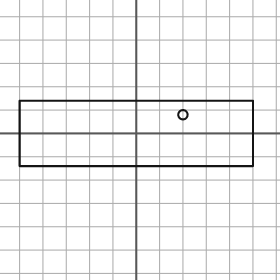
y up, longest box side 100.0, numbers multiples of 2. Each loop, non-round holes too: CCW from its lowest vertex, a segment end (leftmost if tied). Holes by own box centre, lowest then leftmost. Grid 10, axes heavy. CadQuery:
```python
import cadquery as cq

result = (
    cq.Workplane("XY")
    .moveTo(-50.0, -14.0)
    .lineTo(50.0, -14.0)
    .lineTo(50.0, 14.0)
    .lineTo(-50.0, 14.0)
    .close()
    .moveTo(20.0, 8.0)
    .circle(2.0)
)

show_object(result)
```